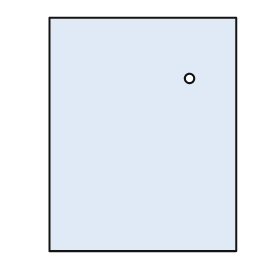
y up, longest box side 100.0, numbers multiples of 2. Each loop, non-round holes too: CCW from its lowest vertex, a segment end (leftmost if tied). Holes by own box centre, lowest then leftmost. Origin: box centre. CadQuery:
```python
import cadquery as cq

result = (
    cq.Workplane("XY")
    .moveTo(-40.0, -50.0)
    .lineTo(40.0, -50.0)
    .lineTo(40.0, 50.0)
    .lineTo(-40.0, 50.0)
    .close()
    .moveTo(20.0, 24.0)
    .circle(2.0)
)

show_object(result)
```